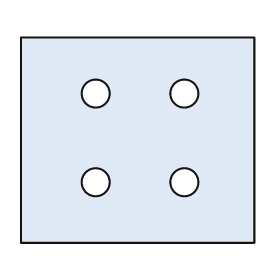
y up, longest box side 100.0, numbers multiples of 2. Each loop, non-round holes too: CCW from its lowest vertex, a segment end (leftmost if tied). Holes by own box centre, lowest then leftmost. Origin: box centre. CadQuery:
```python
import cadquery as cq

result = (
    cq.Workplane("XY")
    .moveTo(-50.0, -44.0)
    .lineTo(50.0, -44.0)
    .lineTo(50.0, 44.0)
    .lineTo(-50.0, 44.0)
    .close()
    .moveTo(-18.0, -18.0)
    .circle(6.0)
    .moveTo(20.0, -18.0)
    .circle(6.0)
    .moveTo(-18.0, 20.0)
    .circle(6.0)
    .moveTo(20.0, 20.0)
    .circle(6.0)
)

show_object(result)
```